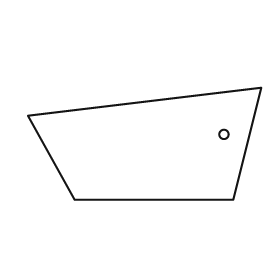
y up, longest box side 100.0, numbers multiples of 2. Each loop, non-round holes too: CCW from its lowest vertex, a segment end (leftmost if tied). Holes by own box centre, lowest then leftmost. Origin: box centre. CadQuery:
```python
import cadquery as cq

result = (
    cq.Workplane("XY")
    .moveTo(-30.0, -24.0)
    .lineTo(38.0, -24.0)
    .lineTo(50.0, 24.0)
    .lineTo(-50.0, 12.0)
    .close()
    .moveTo(34.0, 4.0)
    .circle(2.0)
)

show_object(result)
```